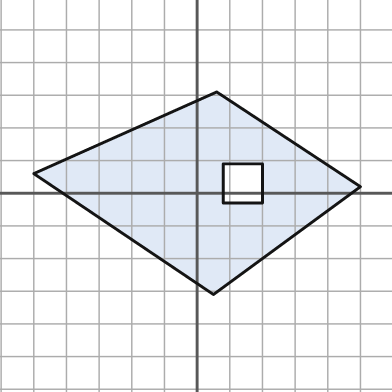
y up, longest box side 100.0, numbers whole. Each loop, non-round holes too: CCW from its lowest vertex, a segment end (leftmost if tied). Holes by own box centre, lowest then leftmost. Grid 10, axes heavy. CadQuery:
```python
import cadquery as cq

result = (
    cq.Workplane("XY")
    .moveTo(5.0, -31.0)
    .lineTo(50.0, 2.0)
    .lineTo(6.0, 31.0)
    .lineTo(-50.0, 6.0)
    .close()
    .moveTo(8.0, -3.0)
    .lineTo(20.0, -3.0)
    .lineTo(20.0, 9.0)
    .lineTo(8.0, 9.0)
    .close()
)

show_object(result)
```